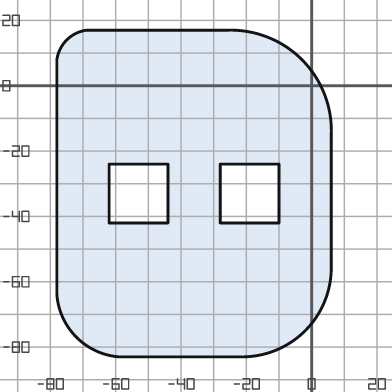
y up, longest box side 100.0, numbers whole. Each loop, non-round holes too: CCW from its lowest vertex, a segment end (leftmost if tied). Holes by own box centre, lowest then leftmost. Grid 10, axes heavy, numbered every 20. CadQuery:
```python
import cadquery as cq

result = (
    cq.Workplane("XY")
    .moveTo(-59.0, -83.0)
    .lineTo(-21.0, -83.0)
    .threePointArc((-2.0, -75.0), (6.0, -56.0))
    .lineTo(6.0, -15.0)
    .threePointArc((-3.0, 8.0), (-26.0, 17.0))
    .lineTo(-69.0, 17.0)
    .threePointArc((-75.0, 14.0), (-78.0, 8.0))
    .lineTo(-78.0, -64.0)
    .threePointArc((-72.0, -77.0), (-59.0, -83.0))
    .close()
    .moveTo(-62.0, -42.0)
    .lineTo(-44.0, -42.0)
    .lineTo(-44.0, -24.0)
    .lineTo(-62.0, -24.0)
    .close()
    .moveTo(-28.0, -42.0)
    .lineTo(-10.0, -42.0)
    .lineTo(-10.0, -24.0)
    .lineTo(-28.0, -24.0)
    .close()
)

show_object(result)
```